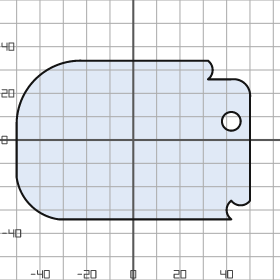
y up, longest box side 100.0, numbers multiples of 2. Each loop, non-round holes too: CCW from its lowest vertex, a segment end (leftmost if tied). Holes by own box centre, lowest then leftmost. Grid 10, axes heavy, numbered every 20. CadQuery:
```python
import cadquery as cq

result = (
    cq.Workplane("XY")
    .moveTo(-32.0, -34.0)
    .lineTo(42.0, -34.0)
    .threePointArc((40.0, -30.0), (42.0, -26.0))
    .threePointArc((46.0, -28.0), (50.0, -26.0))
    .lineTo(50.0, 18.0)
    .threePointArc((48.0, 24.0), (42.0, 26.0))
    .lineTo(32.0, 26.0)
    .threePointArc((34.0, 30.0), (32.0, 34.0))
    .lineTo(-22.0, 34.0)
    .threePointArc((-42.0, 26.0), (-50.0, 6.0))
    .lineTo(-50.0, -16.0)
    .threePointArc((-44.0, -28.0), (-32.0, -34.0))
    .close()
    .moveTo(42.0, 8.0)
    .circle(4.0)
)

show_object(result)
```